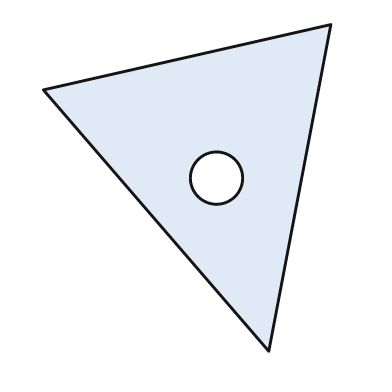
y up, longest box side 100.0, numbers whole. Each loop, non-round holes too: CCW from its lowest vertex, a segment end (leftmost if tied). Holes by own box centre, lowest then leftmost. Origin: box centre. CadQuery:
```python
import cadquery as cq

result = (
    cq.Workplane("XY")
    .moveTo(25.0, -50.0)
    .lineTo(44.0, 50.0)
    .lineTo(-44.0, 30.0)
    .close()
    .moveTo(9.0, 3.0)
    .circle(8.0)
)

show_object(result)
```